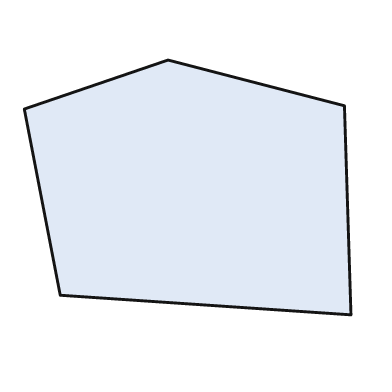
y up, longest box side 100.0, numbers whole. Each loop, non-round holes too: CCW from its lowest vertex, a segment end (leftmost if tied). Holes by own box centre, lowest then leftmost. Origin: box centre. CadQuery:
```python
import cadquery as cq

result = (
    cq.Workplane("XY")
    .moveTo(50.0, -39.0)
    .lineTo(48.0, 25.0)
    .lineTo(-6.0, 39.0)
    .lineTo(-50.0, 24.0)
    .lineTo(-39.0, -33.0)
    .close()
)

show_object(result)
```